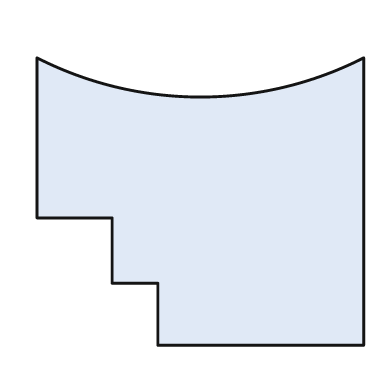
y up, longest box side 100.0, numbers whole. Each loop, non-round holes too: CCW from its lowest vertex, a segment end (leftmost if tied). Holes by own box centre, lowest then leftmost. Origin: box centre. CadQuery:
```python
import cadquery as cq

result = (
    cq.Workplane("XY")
    .moveTo(-13.0, -44.0)
    .lineTo(50.0, -44.0)
    .lineTo(50.0, 44.0)
    .threePointArc((0.0, 32.0), (-50.0, 44.0))
    .lineTo(-50.0, -5.0)
    .lineTo(-27.0, -5.0)
    .lineTo(-27.0, -25.0)
    .lineTo(-13.0, -25.0)
    .close()
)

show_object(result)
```